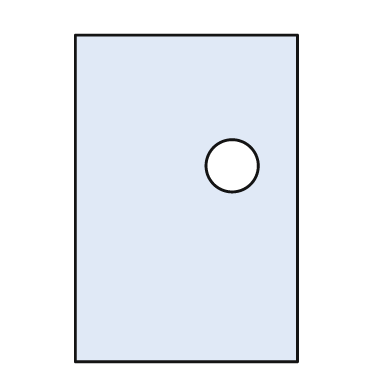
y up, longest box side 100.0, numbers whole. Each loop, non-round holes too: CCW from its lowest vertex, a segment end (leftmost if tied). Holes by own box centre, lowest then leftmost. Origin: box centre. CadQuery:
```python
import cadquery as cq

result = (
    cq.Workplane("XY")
    .moveTo(-34.0, -50.0)
    .lineTo(34.0, -50.0)
    .lineTo(34.0, 50.0)
    .lineTo(-34.0, 50.0)
    .close()
    .moveTo(14.0, 10.0)
    .circle(8.0)
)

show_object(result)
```